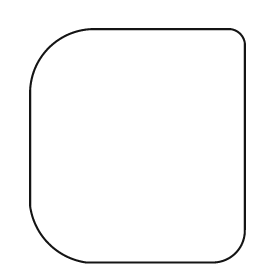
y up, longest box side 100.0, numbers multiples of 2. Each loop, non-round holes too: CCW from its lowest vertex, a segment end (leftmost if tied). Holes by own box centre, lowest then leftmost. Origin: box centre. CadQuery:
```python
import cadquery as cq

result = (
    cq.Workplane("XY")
    .moveTo(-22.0, -50.0)
    .lineTo(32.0, -50.0)
    .threePointArc((42.0, -46.0), (46.0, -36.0))
    .lineTo(46.0, 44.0)
    .threePointArc((44.0, 48.0), (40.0, 50.0))
    .lineTo(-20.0, 50.0)
    .threePointArc((-38.0, 42.0), (-46.0, 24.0))
    .lineTo(-46.0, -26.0)
    .threePointArc((-38.0, -42.0), (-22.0, -50.0))
    .close()
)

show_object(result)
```